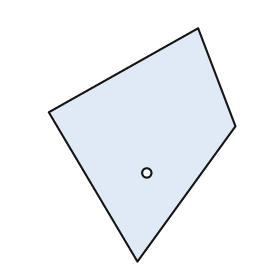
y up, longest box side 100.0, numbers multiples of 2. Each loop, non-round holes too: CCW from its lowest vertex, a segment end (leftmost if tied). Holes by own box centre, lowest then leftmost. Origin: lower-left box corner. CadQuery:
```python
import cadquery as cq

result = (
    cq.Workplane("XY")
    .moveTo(38.0, 0.0)
    .lineTo(80.0, 58.0)
    .lineTo(64.0, 100.0)
    .lineTo(0.0, 64.0)
    .close()
    .moveTo(42.0, 38.0)
    .circle(2.0)
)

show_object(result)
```